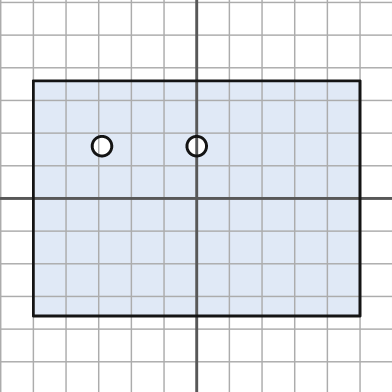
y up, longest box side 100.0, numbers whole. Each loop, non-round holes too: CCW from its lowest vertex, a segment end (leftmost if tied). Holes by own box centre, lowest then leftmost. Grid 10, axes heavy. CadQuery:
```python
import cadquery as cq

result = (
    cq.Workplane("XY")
    .moveTo(-50.0, -36.0)
    .lineTo(50.0, -36.0)
    .lineTo(50.0, 36.0)
    .lineTo(-50.0, 36.0)
    .close()
    .moveTo(-29.0, 16.0)
    .circle(3.0)
    .moveTo(0.0, 16.0)
    .circle(3.0)
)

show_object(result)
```